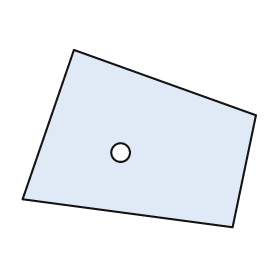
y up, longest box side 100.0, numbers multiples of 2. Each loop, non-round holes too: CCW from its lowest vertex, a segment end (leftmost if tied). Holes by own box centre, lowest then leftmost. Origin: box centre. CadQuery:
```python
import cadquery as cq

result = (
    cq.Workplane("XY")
    .moveTo(40.0, -38.0)
    .lineTo(50.0, 10.0)
    .lineTo(-28.0, 38.0)
    .lineTo(-50.0, -26.0)
    .close()
    .moveTo(-8.0, -6.0)
    .circle(4.0)
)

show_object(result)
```